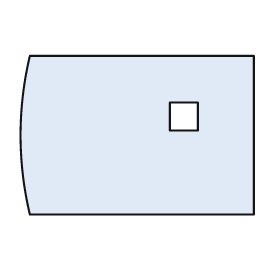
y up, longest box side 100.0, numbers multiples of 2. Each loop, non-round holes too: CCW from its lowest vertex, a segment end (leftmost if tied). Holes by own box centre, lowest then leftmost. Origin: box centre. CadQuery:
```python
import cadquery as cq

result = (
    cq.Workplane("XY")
    .moveTo(-46.0, -34.0)
    .lineTo(50.0, -34.0)
    .lineTo(50.0, 34.0)
    .lineTo(-46.0, 34.0)
    .threePointArc((-50.0, 0.0), (-46.0, -34.0))
    .close()
    .moveTo(14.0, 2.0)
    .lineTo(26.0, 2.0)
    .lineTo(26.0, 14.0)
    .lineTo(14.0, 14.0)
    .close()
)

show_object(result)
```